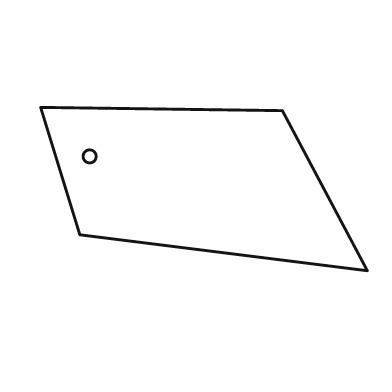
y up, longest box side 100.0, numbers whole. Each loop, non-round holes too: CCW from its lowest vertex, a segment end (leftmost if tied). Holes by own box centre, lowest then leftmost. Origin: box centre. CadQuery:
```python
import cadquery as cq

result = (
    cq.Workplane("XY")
    .moveTo(50.0, -25.0)
    .lineTo(24.0, 24.0)
    .lineTo(-50.0, 25.0)
    .lineTo(-38.0, -14.0)
    .close()
    .moveTo(-35.0, 10.0)
    .circle(2.0)
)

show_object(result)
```